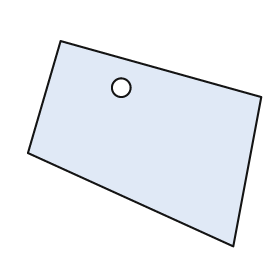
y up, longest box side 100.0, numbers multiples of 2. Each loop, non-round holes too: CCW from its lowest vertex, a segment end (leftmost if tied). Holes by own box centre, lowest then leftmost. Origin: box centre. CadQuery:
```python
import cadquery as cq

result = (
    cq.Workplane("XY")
    .moveTo(38.0, -44.0)
    .lineTo(50.0, 20.0)
    .lineTo(-36.0, 44.0)
    .lineTo(-50.0, -4.0)
    .close()
    .moveTo(-10.0, 24.0)
    .circle(4.0)
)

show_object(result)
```